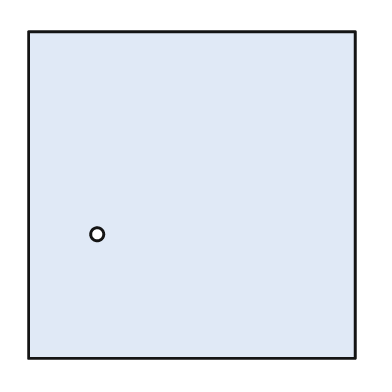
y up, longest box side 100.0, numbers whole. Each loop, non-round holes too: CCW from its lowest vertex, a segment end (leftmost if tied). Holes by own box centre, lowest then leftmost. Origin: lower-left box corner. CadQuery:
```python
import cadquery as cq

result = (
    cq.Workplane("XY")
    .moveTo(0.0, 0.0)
    .lineTo(100.0, 0.0)
    .lineTo(100.0, 100.0)
    .lineTo(0.0, 100.0)
    .close()
    .moveTo(21.0, 38.0)
    .circle(2.0)
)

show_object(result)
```